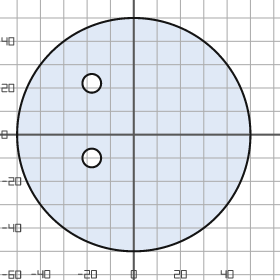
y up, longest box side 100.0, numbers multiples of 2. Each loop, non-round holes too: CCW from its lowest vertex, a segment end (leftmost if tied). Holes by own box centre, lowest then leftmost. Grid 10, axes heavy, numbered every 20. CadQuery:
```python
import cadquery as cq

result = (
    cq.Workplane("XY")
    .moveTo(0.0, 0.0)
    .circle(50.0)
    .moveTo(-18.0, -10.0)
    .circle(4.0)
    .moveTo(-18.0, 22.0)
    .circle(4.0)
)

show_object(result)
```